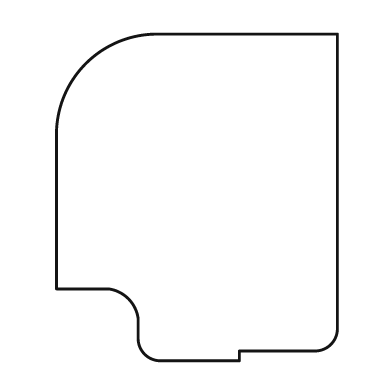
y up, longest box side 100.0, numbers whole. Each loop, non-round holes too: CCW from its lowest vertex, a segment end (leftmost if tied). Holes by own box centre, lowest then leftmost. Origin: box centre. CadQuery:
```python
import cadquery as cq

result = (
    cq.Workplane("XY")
    .moveTo(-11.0, -50.0)
    .lineTo(13.0, -50.0)
    .lineTo(13.0, -47.0)
    .lineTo(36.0, -47.0)
    .threePointArc((41.0, -45.0), (43.0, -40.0))
    .lineTo(43.0, 50.0)
    .lineTo(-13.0, 50.0)
    .threePointArc((-34.0, 41.0), (-43.0, 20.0))
    .lineTo(-43.0, -28.0)
    .lineTo(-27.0, -28.0)
    .threePointArc((-21.0, -31.0), (-18.0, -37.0))
    .lineTo(-18.0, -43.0)
    .threePointArc((-16.0, -48.0), (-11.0, -50.0))
    .close()
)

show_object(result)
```